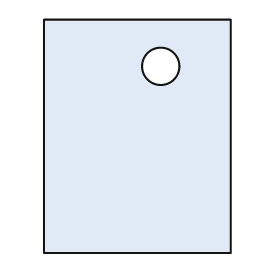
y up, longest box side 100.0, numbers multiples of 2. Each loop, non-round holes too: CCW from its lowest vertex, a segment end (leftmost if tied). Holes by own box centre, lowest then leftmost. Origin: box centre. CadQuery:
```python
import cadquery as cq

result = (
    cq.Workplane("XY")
    .moveTo(-40.0, -50.0)
    .lineTo(40.0, -50.0)
    .lineTo(40.0, 50.0)
    .lineTo(-40.0, 50.0)
    .close()
    .moveTo(10.0, 30.0)
    .circle(8.0)
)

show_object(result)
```